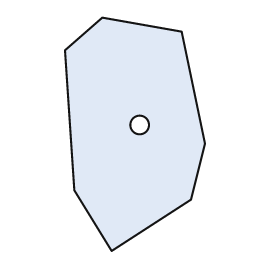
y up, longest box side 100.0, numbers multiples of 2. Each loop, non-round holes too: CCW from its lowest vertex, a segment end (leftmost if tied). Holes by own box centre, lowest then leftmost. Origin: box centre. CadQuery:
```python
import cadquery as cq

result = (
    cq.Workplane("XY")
    .moveTo(-10.0, -50.0)
    .lineTo(24.0, -28.0)
    .lineTo(30.0, -4.0)
    .lineTo(20.0, 44.0)
    .lineTo(-14.0, 50.0)
    .lineTo(-30.0, 36.0)
    .lineTo(-26.0, -24.0)
    .close()
    .moveTo(2.0, 4.0)
    .circle(4.0)
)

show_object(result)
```